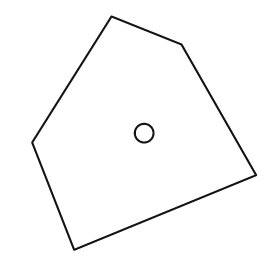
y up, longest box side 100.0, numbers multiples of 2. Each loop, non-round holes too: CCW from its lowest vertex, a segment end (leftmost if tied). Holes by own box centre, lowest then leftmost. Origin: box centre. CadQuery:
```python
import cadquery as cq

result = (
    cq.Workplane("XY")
    .moveTo(-30.0, -50.0)
    .lineTo(48.0, -18.0)
    .lineTo(16.0, 38.0)
    .lineTo(-14.0, 50.0)
    .lineTo(-48.0, -4.0)
    .close()
    .moveTo(0.0, 0.0)
    .circle(4.0)
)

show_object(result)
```